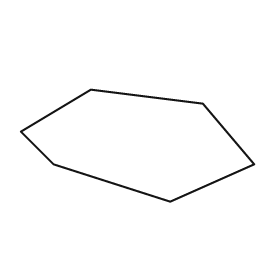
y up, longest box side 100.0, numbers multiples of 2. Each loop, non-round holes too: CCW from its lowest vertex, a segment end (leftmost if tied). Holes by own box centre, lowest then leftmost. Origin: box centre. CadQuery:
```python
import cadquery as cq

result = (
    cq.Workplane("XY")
    .moveTo(14.0, -24.0)
    .lineTo(50.0, -8.0)
    .lineTo(28.0, 18.0)
    .lineTo(-20.0, 24.0)
    .lineTo(-50.0, 6.0)
    .lineTo(-36.0, -8.0)
    .close()
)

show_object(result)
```